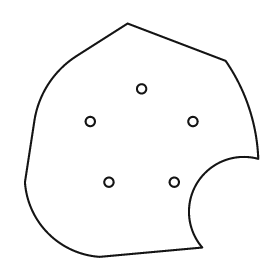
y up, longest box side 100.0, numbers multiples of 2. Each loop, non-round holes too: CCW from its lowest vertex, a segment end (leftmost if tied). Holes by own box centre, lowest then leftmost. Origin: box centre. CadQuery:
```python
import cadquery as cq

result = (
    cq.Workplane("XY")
    .moveTo(-18.0, -50.0)
    .lineTo(26.0, -46.0)
    .threePointArc((24.0, -18.0), (50.0, -8.0))
    .threePointArc((46.0, 14.0), (36.0, 34.0))
    .lineTo(-6.0, 50.0)
    .lineTo(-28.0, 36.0)
    .threePointArc((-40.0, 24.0), (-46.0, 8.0))
    .lineTo(-50.0, -18.0)
    .threePointArc((-40.0, -40.0), (-18.0, -50.0))
    .close()
    .moveTo(-14.0, -18.0)
    .circle(2.0)
    .moveTo(14.0, -18.0)
    .circle(2.0)
    .moveTo(-22.0, 8.0)
    .circle(2.0)
    .moveTo(22.0, 8.0)
    .circle(2.0)
    .moveTo(0.0, 22.0)
    .circle(2.0)
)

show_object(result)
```